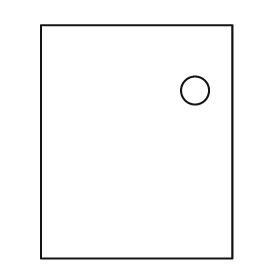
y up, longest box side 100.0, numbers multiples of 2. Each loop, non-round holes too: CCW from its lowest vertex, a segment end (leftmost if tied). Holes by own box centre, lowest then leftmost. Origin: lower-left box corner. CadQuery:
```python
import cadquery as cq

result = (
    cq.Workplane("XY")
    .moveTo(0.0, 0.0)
    .lineTo(82.0, 0.0)
    .lineTo(82.0, 100.0)
    .lineTo(0.0, 100.0)
    .close()
    .moveTo(66.0, 72.0)
    .circle(6.0)
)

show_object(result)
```